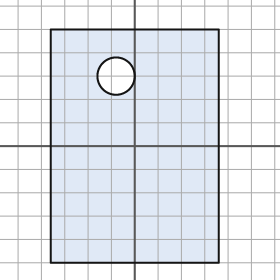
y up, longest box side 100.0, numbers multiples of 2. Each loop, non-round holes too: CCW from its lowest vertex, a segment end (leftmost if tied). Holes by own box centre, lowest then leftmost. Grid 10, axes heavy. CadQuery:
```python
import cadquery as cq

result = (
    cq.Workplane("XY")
    .moveTo(-36.0, -50.0)
    .lineTo(36.0, -50.0)
    .lineTo(36.0, 50.0)
    .lineTo(-36.0, 50.0)
    .close()
    .moveTo(-8.0, 30.0)
    .circle(8.0)
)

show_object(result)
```